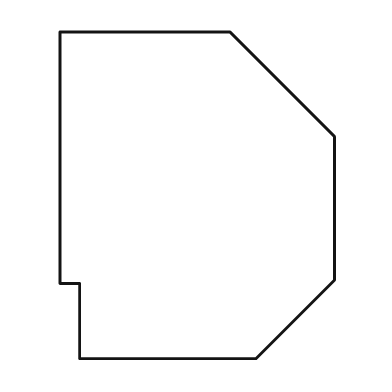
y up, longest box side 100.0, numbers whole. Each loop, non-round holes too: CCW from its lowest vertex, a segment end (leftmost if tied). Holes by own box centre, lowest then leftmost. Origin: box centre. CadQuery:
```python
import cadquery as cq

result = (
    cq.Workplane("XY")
    .moveTo(-36.0, -50.0)
    .lineTo(18.0, -50.0)
    .lineTo(42.0, -26.0)
    .lineTo(42.0, 18.0)
    .lineTo(10.0, 50.0)
    .lineTo(-42.0, 50.0)
    .lineTo(-42.0, -27.0)
    .lineTo(-36.0, -27.0)
    .close()
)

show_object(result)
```